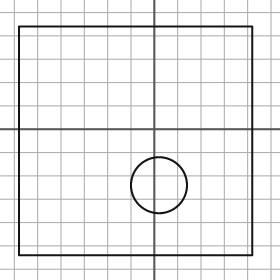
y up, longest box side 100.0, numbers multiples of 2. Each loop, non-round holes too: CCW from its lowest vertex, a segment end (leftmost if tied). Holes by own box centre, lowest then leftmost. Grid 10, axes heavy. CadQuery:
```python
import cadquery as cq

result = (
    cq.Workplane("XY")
    .moveTo(-58.0, -54.0)
    .lineTo(42.0, -54.0)
    .lineTo(42.0, 44.0)
    .lineTo(-58.0, 44.0)
    .close()
    .moveTo(2.0, -24.0)
    .circle(12.0)
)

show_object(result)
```